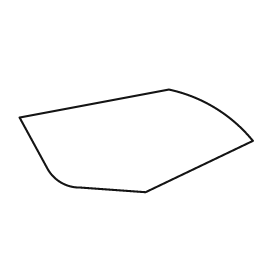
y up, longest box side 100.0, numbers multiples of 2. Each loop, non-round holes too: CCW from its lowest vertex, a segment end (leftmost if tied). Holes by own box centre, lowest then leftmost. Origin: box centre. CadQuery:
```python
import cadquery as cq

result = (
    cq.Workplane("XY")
    .moveTo(4.0, -22.0)
    .lineTo(50.0, 0.0)
    .threePointArc((34.0, 14.0), (14.0, 22.0))
    .lineTo(-50.0, 10.0)
    .lineTo(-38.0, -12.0)
    .threePointArc((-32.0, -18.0), (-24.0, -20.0))
    .close()
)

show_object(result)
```